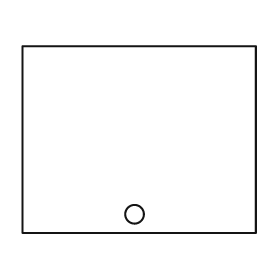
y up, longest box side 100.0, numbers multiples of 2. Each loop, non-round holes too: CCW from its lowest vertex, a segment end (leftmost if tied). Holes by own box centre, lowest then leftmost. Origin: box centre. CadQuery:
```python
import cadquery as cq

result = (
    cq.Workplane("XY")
    .moveTo(-50.0, -40.0)
    .lineTo(50.0, -40.0)
    .lineTo(50.0, 40.0)
    .lineTo(-50.0, 40.0)
    .close()
    .moveTo(-2.0, -32.0)
    .circle(4.0)
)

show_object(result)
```